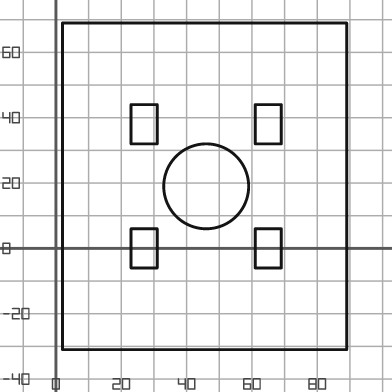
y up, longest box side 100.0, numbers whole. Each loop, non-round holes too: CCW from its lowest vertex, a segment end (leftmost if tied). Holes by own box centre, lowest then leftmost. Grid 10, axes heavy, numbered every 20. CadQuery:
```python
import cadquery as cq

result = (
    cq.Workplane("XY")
    .moveTo(2.0, -31.0)
    .lineTo(89.0, -31.0)
    .lineTo(89.0, 69.0)
    .lineTo(2.0, 69.0)
    .close()
    .moveTo(23.0, -6.0)
    .lineTo(31.0, -6.0)
    .lineTo(31.0, 6.0)
    .lineTo(23.0, 6.0)
    .close()
    .moveTo(61.0, -6.0)
    .lineTo(69.0, -6.0)
    .lineTo(69.0, 6.0)
    .lineTo(61.0, 6.0)
    .close()
    .moveTo(46.0, 19.0)
    .circle(13.0)
    .moveTo(23.0, 32.0)
    .lineTo(31.0, 32.0)
    .lineTo(31.0, 44.0)
    .lineTo(23.0, 44.0)
    .close()
    .moveTo(61.0, 32.0)
    .lineTo(69.0, 32.0)
    .lineTo(69.0, 44.0)
    .lineTo(61.0, 44.0)
    .close()
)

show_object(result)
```